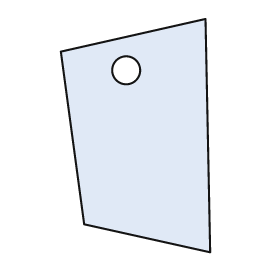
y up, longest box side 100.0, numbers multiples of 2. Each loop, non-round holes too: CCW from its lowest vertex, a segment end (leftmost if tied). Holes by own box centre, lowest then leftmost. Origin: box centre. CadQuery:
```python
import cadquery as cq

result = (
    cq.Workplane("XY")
    .moveTo(32.0, -50.0)
    .lineTo(30.0, 50.0)
    .lineTo(-32.0, 36.0)
    .lineTo(-22.0, -38.0)
    .close()
    .moveTo(-4.0, 28.0)
    .circle(6.0)
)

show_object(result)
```